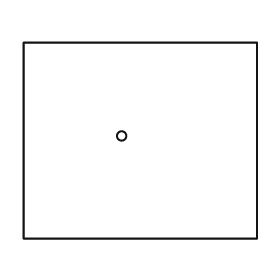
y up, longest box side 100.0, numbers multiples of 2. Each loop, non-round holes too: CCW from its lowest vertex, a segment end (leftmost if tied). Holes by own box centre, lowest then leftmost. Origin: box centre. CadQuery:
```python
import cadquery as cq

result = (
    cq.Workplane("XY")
    .moveTo(-50.0, -42.0)
    .lineTo(50.0, -42.0)
    .lineTo(50.0, 42.0)
    .lineTo(-50.0, 42.0)
    .close()
    .moveTo(-8.0, 2.0)
    .circle(2.0)
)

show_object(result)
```